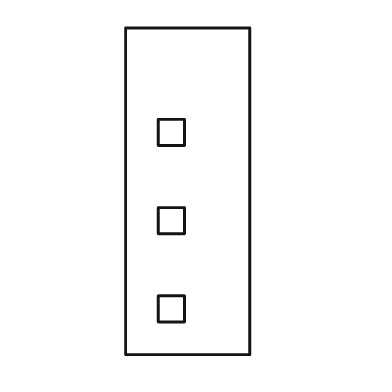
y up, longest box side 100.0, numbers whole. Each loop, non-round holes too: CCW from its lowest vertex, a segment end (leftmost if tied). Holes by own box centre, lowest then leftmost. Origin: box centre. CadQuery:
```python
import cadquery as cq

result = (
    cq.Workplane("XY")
    .moveTo(-19.0, -50.0)
    .lineTo(19.0, -50.0)
    .lineTo(19.0, 50.0)
    .lineTo(-19.0, 50.0)
    .close()
    .moveTo(-9.0, -40.0)
    .lineTo(-1.0, -40.0)
    .lineTo(-1.0, -32.0)
    .lineTo(-9.0, -32.0)
    .close()
    .moveTo(-9.0, -13.0)
    .lineTo(-1.0, -13.0)
    .lineTo(-1.0, -5.0)
    .lineTo(-9.0, -5.0)
    .close()
    .moveTo(-9.0, 14.0)
    .lineTo(-1.0, 14.0)
    .lineTo(-1.0, 22.0)
    .lineTo(-9.0, 22.0)
    .close()
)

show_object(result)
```